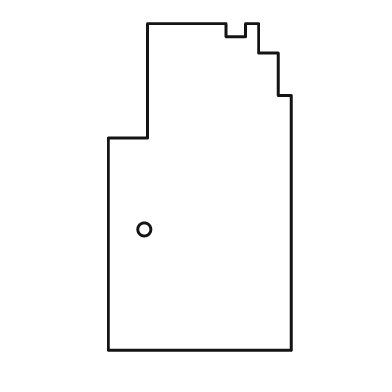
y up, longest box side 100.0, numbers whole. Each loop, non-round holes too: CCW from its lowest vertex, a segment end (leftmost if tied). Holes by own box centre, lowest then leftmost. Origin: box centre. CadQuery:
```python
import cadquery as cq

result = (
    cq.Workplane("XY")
    .moveTo(-28.0, -50.0)
    .lineTo(28.0, -50.0)
    .lineTo(28.0, 28.0)
    .lineTo(24.0, 28.0)
    .lineTo(24.0, 41.0)
    .lineTo(18.0, 41.0)
    .lineTo(18.0, 50.0)
    .lineTo(14.0, 50.0)
    .lineTo(14.0, 46.0)
    .lineTo(8.0, 46.0)
    .lineTo(8.0, 50.0)
    .lineTo(-16.0, 50.0)
    .lineTo(-16.0, 15.0)
    .lineTo(-28.0, 15.0)
    .close()
    .moveTo(-17.0, -13.0)
    .circle(2.0)
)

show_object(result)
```